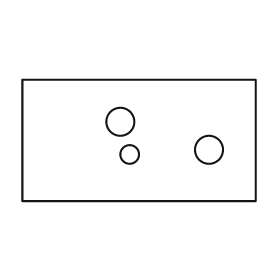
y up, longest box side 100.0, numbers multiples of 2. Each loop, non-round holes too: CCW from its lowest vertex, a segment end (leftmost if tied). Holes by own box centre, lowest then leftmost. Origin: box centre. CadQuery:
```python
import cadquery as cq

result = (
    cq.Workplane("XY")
    .moveTo(-50.0, -26.0)
    .lineTo(50.0, -26.0)
    .lineTo(50.0, 26.0)
    .lineTo(-50.0, 26.0)
    .close()
    .moveTo(-4.0, -6.0)
    .circle(4.0)
    .moveTo(30.0, -4.0)
    .circle(6.0)
    .moveTo(-8.0, 8.0)
    .circle(6.0)
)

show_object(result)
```